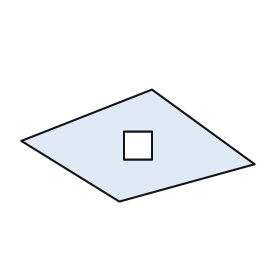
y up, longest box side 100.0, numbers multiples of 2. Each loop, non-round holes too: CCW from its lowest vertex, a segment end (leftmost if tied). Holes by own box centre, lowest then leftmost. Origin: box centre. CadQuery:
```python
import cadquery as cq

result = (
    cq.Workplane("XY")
    .moveTo(-8.0, -24.0)
    .lineTo(50.0, -8.0)
    .lineTo(6.0, 24.0)
    .lineTo(-50.0, 2.0)
    .close()
    .moveTo(-6.0, -6.0)
    .lineTo(6.0, -6.0)
    .lineTo(6.0, 6.0)
    .lineTo(-6.0, 6.0)
    .close()
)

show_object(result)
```